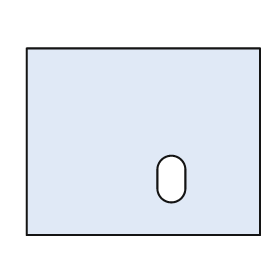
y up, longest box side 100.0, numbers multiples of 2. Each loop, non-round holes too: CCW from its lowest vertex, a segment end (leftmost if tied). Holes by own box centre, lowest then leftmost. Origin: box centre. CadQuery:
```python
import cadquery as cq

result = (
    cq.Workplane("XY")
    .moveTo(-50.0, -40.0)
    .lineTo(50.0, -40.0)
    .lineTo(50.0, 40.0)
    .lineTo(-50.0, 40.0)
    .close()
    .moveTo(6.0, -20.0)
    .threePointArc((12.0, -26.0), (18.0, -20.0))
    .lineTo(18.0, -12.0)
    .threePointArc((12.0, -6.0), (6.0, -12.0))
    .close()
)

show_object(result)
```